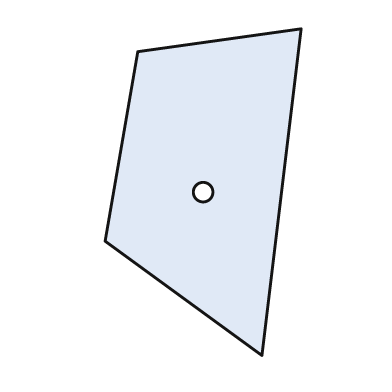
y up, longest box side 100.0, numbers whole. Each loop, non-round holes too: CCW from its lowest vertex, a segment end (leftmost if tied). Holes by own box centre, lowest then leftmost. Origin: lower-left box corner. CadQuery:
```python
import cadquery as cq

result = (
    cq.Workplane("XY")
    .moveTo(48.0, 0.0)
    .lineTo(60.0, 100.0)
    .lineTo(10.0, 93.0)
    .lineTo(0.0, 35.0)
    .close()
    .moveTo(30.0, 50.0)
    .circle(3.0)
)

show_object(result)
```